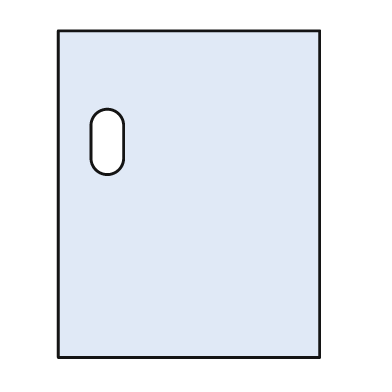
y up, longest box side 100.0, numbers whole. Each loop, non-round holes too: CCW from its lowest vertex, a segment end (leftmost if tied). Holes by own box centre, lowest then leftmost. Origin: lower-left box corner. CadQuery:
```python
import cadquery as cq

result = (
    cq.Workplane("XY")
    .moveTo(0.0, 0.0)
    .lineTo(80.0, 0.0)
    .lineTo(80.0, 100.0)
    .lineTo(0.0, 100.0)
    .close()
    .moveTo(10.0, 61.0)
    .threePointArc((15.0, 56.0), (20.0, 61.0))
    .lineTo(20.0, 71.0)
    .threePointArc((15.0, 76.0), (10.0, 71.0))
    .close()
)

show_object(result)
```